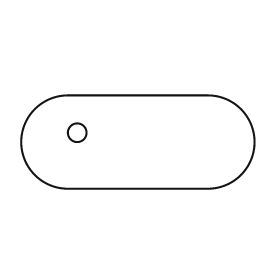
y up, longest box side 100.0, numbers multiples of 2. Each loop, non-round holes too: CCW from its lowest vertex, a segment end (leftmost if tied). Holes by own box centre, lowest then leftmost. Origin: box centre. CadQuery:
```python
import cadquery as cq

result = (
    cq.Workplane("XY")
    .moveTo(-30.0, -20.0)
    .lineTo(30.0, -20.0)
    .threePointArc((50.0, 0.0), (30.0, 20.0))
    .lineTo(-30.0, 20.0)
    .threePointArc((-50.0, 0.0), (-30.0, -20.0))
    .close()
    .moveTo(-26.0, 4.0)
    .circle(4.0)
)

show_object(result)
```